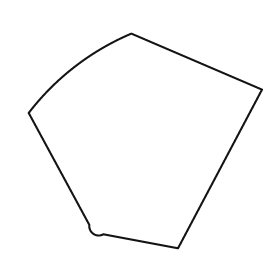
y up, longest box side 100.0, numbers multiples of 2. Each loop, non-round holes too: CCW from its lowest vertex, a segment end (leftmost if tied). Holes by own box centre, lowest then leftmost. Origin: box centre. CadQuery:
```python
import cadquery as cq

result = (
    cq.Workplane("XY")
    .moveTo(14.0, -46.0)
    .lineTo(50.0, 22.0)
    .lineTo(-6.0, 46.0)
    .threePointArc((-30.0, 32.0), (-50.0, 12.0))
    .lineTo(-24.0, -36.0)
    .threePointArc((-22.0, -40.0), (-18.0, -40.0))
    .close()
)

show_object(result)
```